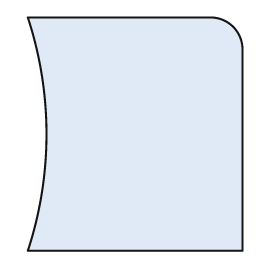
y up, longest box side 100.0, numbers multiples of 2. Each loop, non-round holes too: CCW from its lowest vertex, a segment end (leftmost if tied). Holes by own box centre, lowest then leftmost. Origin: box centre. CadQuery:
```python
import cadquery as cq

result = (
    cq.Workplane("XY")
    .moveTo(-46.0, -50.0)
    .lineTo(46.0, -50.0)
    .lineTo(46.0, 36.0)
    .threePointArc((42.0, 46.0), (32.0, 50.0))
    .lineTo(-46.0, 50.0)
    .threePointArc((-38.0, 0.0), (-46.0, -50.0))
    .close()
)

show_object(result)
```